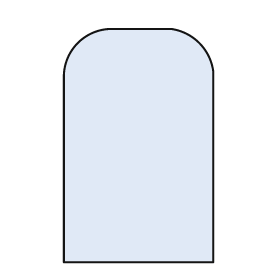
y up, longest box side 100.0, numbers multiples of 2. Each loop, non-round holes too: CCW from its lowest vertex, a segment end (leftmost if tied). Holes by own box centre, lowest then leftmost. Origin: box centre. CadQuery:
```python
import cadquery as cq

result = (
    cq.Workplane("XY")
    .moveTo(-32.0, -50.0)
    .lineTo(32.0, -50.0)
    .lineTo(32.0, 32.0)
    .threePointArc((26.0, 44.0), (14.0, 50.0))
    .lineTo(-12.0, 50.0)
    .threePointArc((-26.0, 44.0), (-32.0, 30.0))
    .close()
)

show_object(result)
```